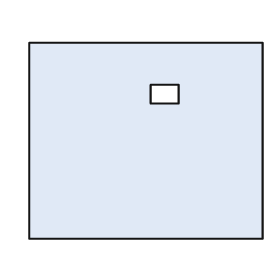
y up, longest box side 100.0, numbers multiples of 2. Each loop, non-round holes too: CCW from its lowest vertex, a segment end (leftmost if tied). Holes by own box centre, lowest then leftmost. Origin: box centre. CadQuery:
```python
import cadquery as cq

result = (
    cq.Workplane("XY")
    .moveTo(-50.0, -42.0)
    .lineTo(50.0, -42.0)
    .lineTo(50.0, 42.0)
    .lineTo(-50.0, 42.0)
    .close()
    .moveTo(2.0, 16.0)
    .lineTo(14.0, 16.0)
    .lineTo(14.0, 24.0)
    .lineTo(2.0, 24.0)
    .close()
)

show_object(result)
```